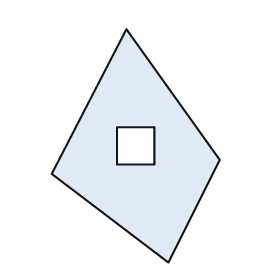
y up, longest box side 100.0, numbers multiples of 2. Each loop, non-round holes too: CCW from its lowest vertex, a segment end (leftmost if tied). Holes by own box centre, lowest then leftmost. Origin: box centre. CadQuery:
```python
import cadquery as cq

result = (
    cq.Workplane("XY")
    .moveTo(14.0, -50.0)
    .lineTo(36.0, -6.0)
    .lineTo(-4.0, 50.0)
    .lineTo(-36.0, -12.0)
    .close()
    .moveTo(-8.0, -8.0)
    .lineTo(8.0, -8.0)
    .lineTo(8.0, 8.0)
    .lineTo(-8.0, 8.0)
    .close()
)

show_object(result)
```